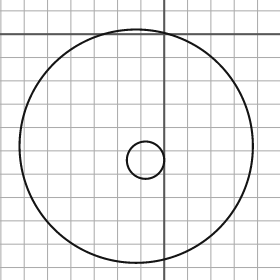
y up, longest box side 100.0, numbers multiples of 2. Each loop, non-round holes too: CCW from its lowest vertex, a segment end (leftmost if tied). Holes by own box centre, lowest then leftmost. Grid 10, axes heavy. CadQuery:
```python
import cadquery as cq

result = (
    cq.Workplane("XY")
    .moveTo(-12.0, -48.0)
    .circle(50.0)
    .moveTo(-8.0, -54.0)
    .circle(8.0)
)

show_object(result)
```